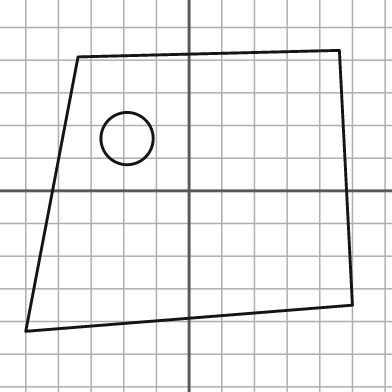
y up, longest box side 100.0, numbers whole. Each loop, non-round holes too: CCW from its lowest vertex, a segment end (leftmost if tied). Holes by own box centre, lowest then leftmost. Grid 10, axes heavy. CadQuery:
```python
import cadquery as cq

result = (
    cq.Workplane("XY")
    .moveTo(-50.0, -43.0)
    .lineTo(50.0, -35.0)
    .lineTo(46.0, 43.0)
    .lineTo(-34.0, 41.0)
    .close()
    .moveTo(-19.0, 16.0)
    .circle(8.0)
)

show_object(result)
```